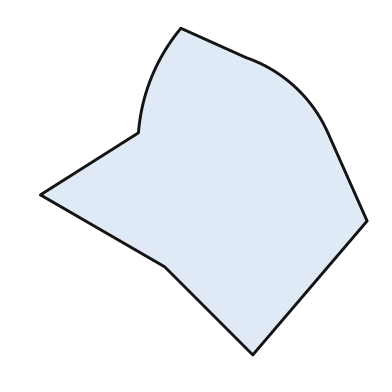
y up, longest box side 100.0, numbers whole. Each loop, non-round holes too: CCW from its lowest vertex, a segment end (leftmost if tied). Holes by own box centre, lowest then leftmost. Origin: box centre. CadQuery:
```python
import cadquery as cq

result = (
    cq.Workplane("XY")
    .moveTo(15.0, -50.0)
    .lineTo(50.0, -9.0)
    .lineTo(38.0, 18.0)
    .threePointArc((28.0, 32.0), (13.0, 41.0))
    .lineTo(-7.0, 50.0)
    .threePointArc((-16.0, 35.0), (-20.0, 18.0))
    .lineTo(-50.0, -1.0)
    .lineTo(-12.0, -23.0)
    .close()
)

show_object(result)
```